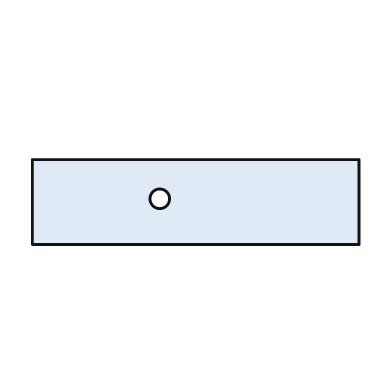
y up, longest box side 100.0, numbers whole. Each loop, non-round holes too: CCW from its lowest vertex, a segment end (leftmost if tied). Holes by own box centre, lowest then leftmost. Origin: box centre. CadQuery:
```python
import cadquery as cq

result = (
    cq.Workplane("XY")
    .moveTo(-50.0, -13.0)
    .lineTo(50.0, -13.0)
    .lineTo(50.0, 13.0)
    .lineTo(-50.0, 13.0)
    .close()
    .moveTo(-11.0, 1.0)
    .circle(3.0)
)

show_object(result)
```